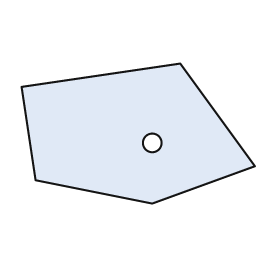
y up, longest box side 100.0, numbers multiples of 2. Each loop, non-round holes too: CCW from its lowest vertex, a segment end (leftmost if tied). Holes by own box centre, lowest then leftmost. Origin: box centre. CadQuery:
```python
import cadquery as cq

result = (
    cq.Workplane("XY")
    .moveTo(6.0, -30.0)
    .lineTo(50.0, -14.0)
    .lineTo(18.0, 30.0)
    .lineTo(-50.0, 20.0)
    .lineTo(-44.0, -20.0)
    .close()
    .moveTo(6.0, -4.0)
    .circle(4.0)
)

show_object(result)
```